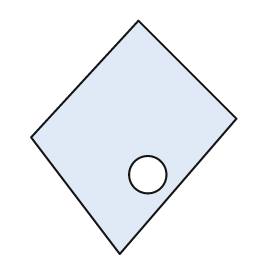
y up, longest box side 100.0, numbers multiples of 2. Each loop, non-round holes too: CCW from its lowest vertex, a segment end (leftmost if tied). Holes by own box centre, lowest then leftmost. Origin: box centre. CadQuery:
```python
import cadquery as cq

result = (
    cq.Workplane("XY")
    .moveTo(-6.0, -50.0)
    .lineTo(44.0, 8.0)
    .lineTo(2.0, 50.0)
    .lineTo(-44.0, 0.0)
    .close()
    .moveTo(6.0, -16.0)
    .circle(8.0)
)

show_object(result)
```